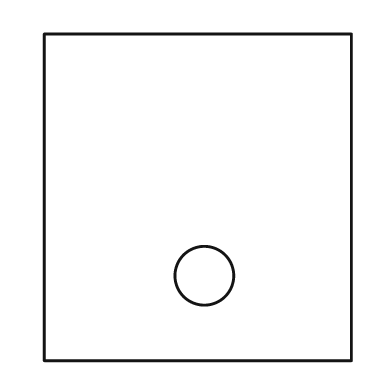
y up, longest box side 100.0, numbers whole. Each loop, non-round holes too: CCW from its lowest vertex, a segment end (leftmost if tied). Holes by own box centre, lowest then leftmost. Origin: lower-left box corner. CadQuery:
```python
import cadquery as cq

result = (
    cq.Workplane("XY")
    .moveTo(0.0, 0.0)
    .lineTo(94.0, 0.0)
    .lineTo(94.0, 100.0)
    .lineTo(0.0, 100.0)
    .close()
    .moveTo(49.0, 26.0)
    .circle(9.0)
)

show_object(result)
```